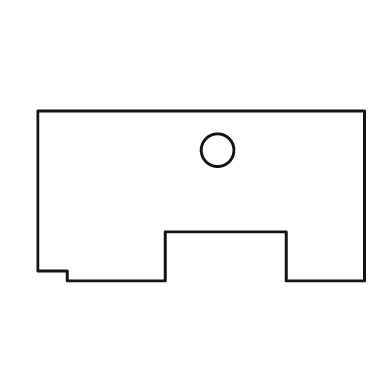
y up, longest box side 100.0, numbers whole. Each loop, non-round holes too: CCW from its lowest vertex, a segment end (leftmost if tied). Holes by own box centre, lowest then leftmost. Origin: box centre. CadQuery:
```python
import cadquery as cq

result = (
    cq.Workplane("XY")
    .moveTo(-41.0, -26.0)
    .lineTo(-11.0, -26.0)
    .lineTo(-11.0, -11.0)
    .lineTo(26.0, -11.0)
    .lineTo(26.0, -26.0)
    .lineTo(50.0, -26.0)
    .lineTo(50.0, 26.0)
    .lineTo(-50.0, 26.0)
    .lineTo(-50.0, -23.0)
    .lineTo(-41.0, -23.0)
    .close()
    .moveTo(5.0, 14.0)
    .circle(5.0)
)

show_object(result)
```